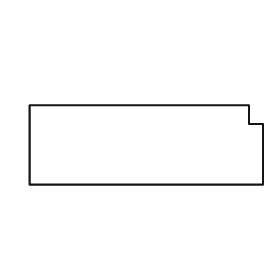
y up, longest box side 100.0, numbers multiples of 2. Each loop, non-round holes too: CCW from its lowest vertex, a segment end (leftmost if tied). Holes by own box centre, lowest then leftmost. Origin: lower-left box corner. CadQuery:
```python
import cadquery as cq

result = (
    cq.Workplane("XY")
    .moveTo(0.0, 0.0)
    .lineTo(100.0, 0.0)
    .lineTo(100.0, 26.0)
    .lineTo(94.0, 26.0)
    .lineTo(94.0, 34.0)
    .lineTo(0.0, 34.0)
    .close()
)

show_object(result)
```